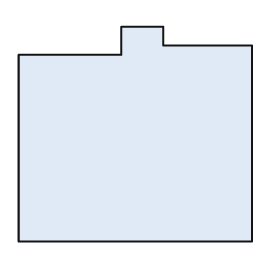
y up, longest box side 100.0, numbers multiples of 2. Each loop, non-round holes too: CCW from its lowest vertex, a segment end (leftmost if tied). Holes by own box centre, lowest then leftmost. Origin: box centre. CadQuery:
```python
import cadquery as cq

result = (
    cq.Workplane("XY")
    .moveTo(-50.0, -46.0)
    .lineTo(50.0, -46.0)
    .lineTo(50.0, 38.0)
    .lineTo(12.0, 38.0)
    .lineTo(12.0, 46.0)
    .lineTo(-6.0, 46.0)
    .lineTo(-6.0, 34.0)
    .lineTo(-50.0, 34.0)
    .close()
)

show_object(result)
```